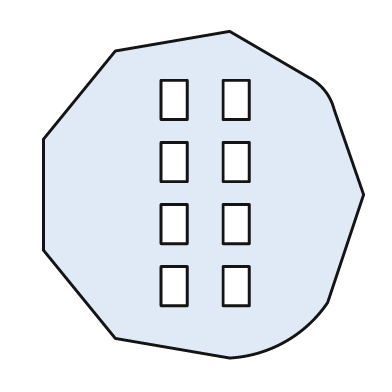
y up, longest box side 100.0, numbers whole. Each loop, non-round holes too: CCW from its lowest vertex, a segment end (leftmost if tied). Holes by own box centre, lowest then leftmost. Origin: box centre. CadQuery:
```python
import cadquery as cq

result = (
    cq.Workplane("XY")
    .moveTo(8.0, -50.0)
    .threePointArc((25.0, -45.0), (38.0, -33.0))
    .lineTo(49.0, 0.0)
    .lineTo(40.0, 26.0)
    .threePointArc((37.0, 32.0), (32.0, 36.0))
    .lineTo(8.0, 50.0)
    .lineTo(-27.0, 44.0)
    .lineTo(-49.0, 17.0)
    .lineTo(-49.0, -17.0)
    .lineTo(-27.0, -44.0)
    .close()
    .moveTo(-13.0, -34.0)
    .lineTo(-5.0, -34.0)
    .lineTo(-5.0, -22.0)
    .lineTo(-13.0, -22.0)
    .close()
    .moveTo(6.0, -34.0)
    .lineTo(14.0, -34.0)
    .lineTo(14.0, -22.0)
    .lineTo(6.0, -22.0)
    .close()
    .moveTo(-13.0, -15.0)
    .lineTo(-5.0, -15.0)
    .lineTo(-5.0, -3.0)
    .lineTo(-13.0, -3.0)
    .close()
    .moveTo(6.0, -15.0)
    .lineTo(14.0, -15.0)
    .lineTo(14.0, -3.0)
    .lineTo(6.0, -3.0)
    .close()
    .moveTo(-13.0, 4.0)
    .lineTo(-5.0, 4.0)
    .lineTo(-5.0, 16.0)
    .lineTo(-13.0, 16.0)
    .close()
    .moveTo(6.0, 4.0)
    .lineTo(14.0, 4.0)
    .lineTo(14.0, 16.0)
    .lineTo(6.0, 16.0)
    .close()
    .moveTo(-13.0, 23.0)
    .lineTo(-5.0, 23.0)
    .lineTo(-5.0, 35.0)
    .lineTo(-13.0, 35.0)
    .close()
    .moveTo(6.0, 23.0)
    .lineTo(14.0, 23.0)
    .lineTo(14.0, 35.0)
    .lineTo(6.0, 35.0)
    .close()
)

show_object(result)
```